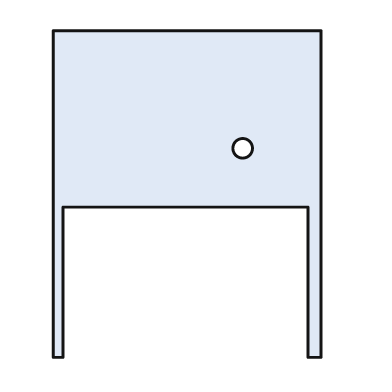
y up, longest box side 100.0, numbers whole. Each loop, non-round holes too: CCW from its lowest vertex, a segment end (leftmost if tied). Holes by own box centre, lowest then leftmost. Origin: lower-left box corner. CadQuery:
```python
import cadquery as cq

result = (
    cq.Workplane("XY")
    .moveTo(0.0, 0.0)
    .lineTo(3.0, 0.0)
    .lineTo(3.0, 46.0)
    .lineTo(78.0, 46.0)
    .lineTo(78.0, 0.0)
    .lineTo(82.0, 0.0)
    .lineTo(82.0, 100.0)
    .lineTo(0.0, 100.0)
    .close()
    .moveTo(58.0, 64.0)
    .circle(3.0)
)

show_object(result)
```